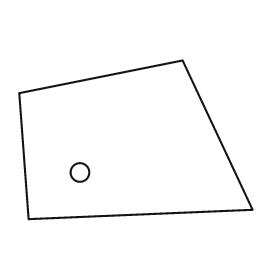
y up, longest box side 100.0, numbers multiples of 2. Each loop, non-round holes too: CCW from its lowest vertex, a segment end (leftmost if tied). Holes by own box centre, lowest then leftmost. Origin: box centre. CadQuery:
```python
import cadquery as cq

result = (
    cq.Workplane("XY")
    .moveTo(-46.0, -34.0)
    .lineTo(50.0, -30.0)
    .lineTo(20.0, 34.0)
    .lineTo(-50.0, 20.0)
    .close()
    .moveTo(-24.0, -14.0)
    .circle(4.0)
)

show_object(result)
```